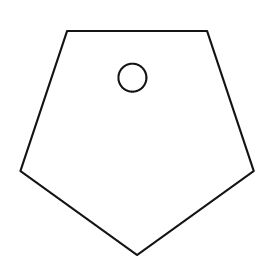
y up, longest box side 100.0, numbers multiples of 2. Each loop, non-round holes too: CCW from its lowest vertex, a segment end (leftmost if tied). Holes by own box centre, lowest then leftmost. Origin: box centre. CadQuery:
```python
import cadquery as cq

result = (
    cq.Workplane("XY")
    .moveTo(0.0, -48.0)
    .lineTo(50.0, -12.0)
    .lineTo(30.0, 48.0)
    .lineTo(-30.0, 48.0)
    .lineTo(-50.0, -12.0)
    .close()
    .moveTo(-2.0, 28.0)
    .circle(6.0)
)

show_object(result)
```